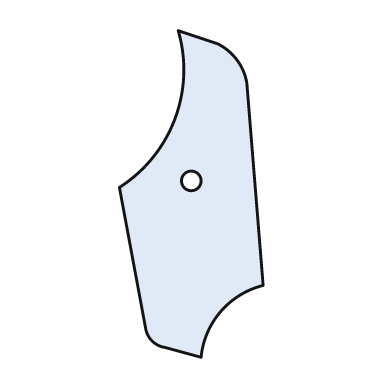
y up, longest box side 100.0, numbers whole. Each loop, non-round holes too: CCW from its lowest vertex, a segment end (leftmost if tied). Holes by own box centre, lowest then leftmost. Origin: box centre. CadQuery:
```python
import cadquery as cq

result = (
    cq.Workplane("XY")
    .moveTo(3.0, -50.0)
    .threePointArc((9.0, -36.0), (22.0, -28.0))
    .lineTo(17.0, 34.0)
    .threePointArc((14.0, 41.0), (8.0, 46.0))
    .lineTo(-4.0, 50.0)
    .threePointArc((-5.0, 23.0), (-22.0, 2.0))
    .lineTo(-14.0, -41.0)
    .threePointArc((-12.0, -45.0), (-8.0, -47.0))
    .close()
    .moveTo(0.0, 4.0)
    .circle(3.0)
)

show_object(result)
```